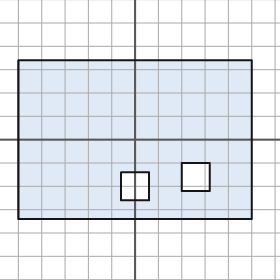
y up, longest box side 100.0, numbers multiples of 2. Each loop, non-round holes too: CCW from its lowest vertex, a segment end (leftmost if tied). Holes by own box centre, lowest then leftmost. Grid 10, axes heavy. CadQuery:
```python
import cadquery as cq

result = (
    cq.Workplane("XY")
    .moveTo(-50.0, -34.0)
    .lineTo(50.0, -34.0)
    .lineTo(50.0, 34.0)
    .lineTo(-50.0, 34.0)
    .close()
    .moveTo(-6.0, -26.0)
    .lineTo(6.0, -26.0)
    .lineTo(6.0, -14.0)
    .lineTo(-6.0, -14.0)
    .close()
    .moveTo(20.0, -22.0)
    .lineTo(32.0, -22.0)
    .lineTo(32.0, -10.0)
    .lineTo(20.0, -10.0)
    .close()
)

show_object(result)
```